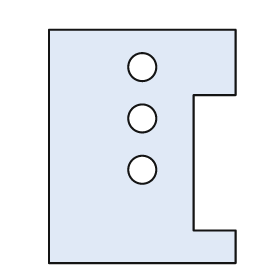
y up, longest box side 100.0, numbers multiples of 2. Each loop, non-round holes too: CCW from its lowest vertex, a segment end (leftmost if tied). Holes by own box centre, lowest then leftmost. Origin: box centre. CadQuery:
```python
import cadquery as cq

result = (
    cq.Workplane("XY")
    .moveTo(-40.0, -50.0)
    .lineTo(40.0, -50.0)
    .lineTo(40.0, -36.0)
    .lineTo(22.0, -36.0)
    .lineTo(22.0, 22.0)
    .lineTo(40.0, 22.0)
    .lineTo(40.0, 50.0)
    .lineTo(-40.0, 50.0)
    .close()
    .moveTo(0.0, -10.0)
    .circle(6.0)
    .moveTo(0.0, 12.0)
    .circle(6.0)
    .moveTo(0.0, 34.0)
    .circle(6.0)
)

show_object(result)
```